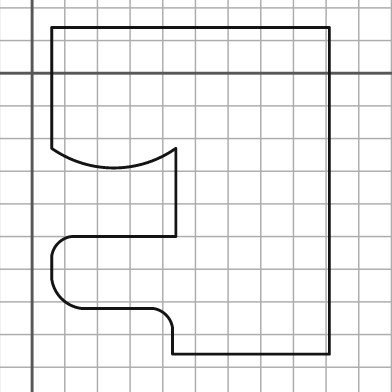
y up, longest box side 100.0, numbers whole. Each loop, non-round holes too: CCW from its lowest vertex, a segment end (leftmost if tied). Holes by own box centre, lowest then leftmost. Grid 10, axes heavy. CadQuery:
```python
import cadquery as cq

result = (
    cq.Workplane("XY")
    .moveTo(43.0, -86.0)
    .lineTo(91.0, -86.0)
    .lineTo(91.0, 14.0)
    .lineTo(6.0, 14.0)
    .lineTo(6.0, -23.0)
    .threePointArc((25.0, -29.0), (44.0, -23.0))
    .lineTo(44.0, -50.0)
    .lineTo(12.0, -50.0)
    .threePointArc((8.0, -52.0), (6.0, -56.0))
    .lineTo(6.0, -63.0)
    .threePointArc((9.0, -69.0), (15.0, -72.0))
    .lineTo(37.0, -72.0)
    .threePointArc((41.0, -74.0), (43.0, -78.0))
    .close()
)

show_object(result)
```